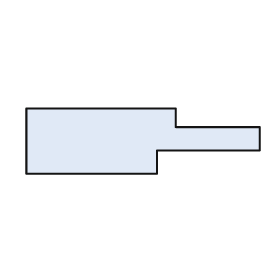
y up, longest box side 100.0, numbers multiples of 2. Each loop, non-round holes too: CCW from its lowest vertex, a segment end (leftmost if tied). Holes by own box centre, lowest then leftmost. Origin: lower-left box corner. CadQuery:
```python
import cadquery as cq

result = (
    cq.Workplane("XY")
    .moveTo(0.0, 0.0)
    .lineTo(56.0, 0.0)
    .lineTo(56.0, 10.0)
    .lineTo(100.0, 10.0)
    .lineTo(100.0, 20.0)
    .lineTo(64.0, 20.0)
    .lineTo(64.0, 28.0)
    .lineTo(0.0, 28.0)
    .close()
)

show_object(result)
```